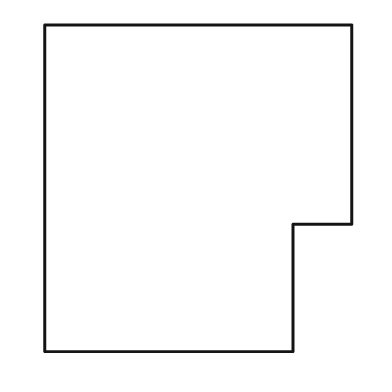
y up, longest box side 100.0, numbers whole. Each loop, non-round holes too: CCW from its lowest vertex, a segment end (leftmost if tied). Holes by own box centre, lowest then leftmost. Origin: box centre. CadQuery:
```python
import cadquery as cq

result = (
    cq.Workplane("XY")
    .moveTo(-47.0, -50.0)
    .lineTo(29.0, -50.0)
    .lineTo(29.0, -11.0)
    .lineTo(47.0, -11.0)
    .lineTo(47.0, 50.0)
    .lineTo(-47.0, 50.0)
    .close()
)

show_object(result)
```